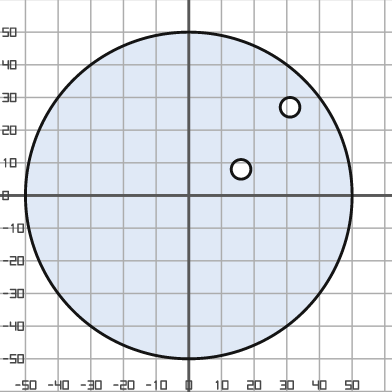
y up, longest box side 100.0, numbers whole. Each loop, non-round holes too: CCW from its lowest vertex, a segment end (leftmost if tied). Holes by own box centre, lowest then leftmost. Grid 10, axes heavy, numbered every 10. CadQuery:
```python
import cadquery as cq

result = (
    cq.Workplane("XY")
    .moveTo(0.0, 0.0)
    .circle(50.0)
    .moveTo(16.0, 8.0)
    .circle(3.0)
    .moveTo(31.0, 27.0)
    .circle(3.0)
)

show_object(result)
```